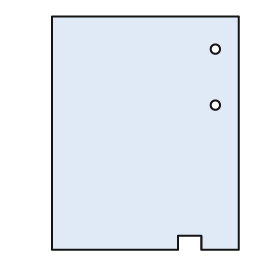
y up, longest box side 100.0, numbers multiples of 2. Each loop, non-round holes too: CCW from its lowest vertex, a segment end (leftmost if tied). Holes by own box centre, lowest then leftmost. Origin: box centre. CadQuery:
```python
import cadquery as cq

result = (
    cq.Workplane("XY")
    .moveTo(-40.0, -50.0)
    .lineTo(14.0, -50.0)
    .lineTo(14.0, -44.0)
    .lineTo(24.0, -44.0)
    .lineTo(24.0, -50.0)
    .lineTo(40.0, -50.0)
    .lineTo(40.0, 50.0)
    .lineTo(-40.0, 50.0)
    .close()
    .moveTo(30.0, 12.0)
    .circle(2.0)
    .moveTo(30.0, 36.0)
    .circle(2.0)
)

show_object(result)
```